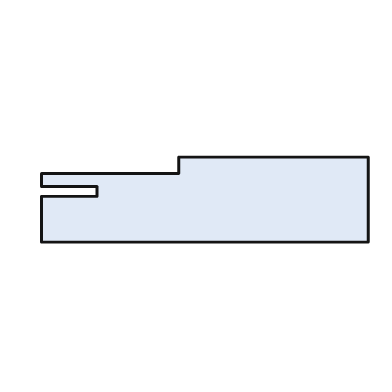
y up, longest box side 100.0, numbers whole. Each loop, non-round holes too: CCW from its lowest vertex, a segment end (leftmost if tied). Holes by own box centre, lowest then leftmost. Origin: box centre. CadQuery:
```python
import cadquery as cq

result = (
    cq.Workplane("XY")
    .moveTo(-50.0, -13.0)
    .lineTo(50.0, -13.0)
    .lineTo(50.0, 13.0)
    .lineTo(-8.0, 13.0)
    .lineTo(-8.0, 8.0)
    .lineTo(-50.0, 8.0)
    .lineTo(-50.0, 4.0)
    .lineTo(-33.0, 4.0)
    .lineTo(-33.0, 1.0)
    .lineTo(-50.0, 1.0)
    .close()
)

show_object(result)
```